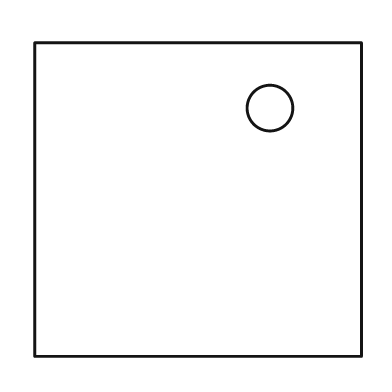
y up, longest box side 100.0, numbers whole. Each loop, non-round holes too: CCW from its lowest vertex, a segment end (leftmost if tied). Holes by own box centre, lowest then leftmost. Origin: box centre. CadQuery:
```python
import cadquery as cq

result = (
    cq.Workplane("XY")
    .moveTo(-50.0, -48.0)
    .lineTo(50.0, -48.0)
    .lineTo(50.0, 48.0)
    .lineTo(-50.0, 48.0)
    .close()
    .moveTo(22.0, 28.0)
    .circle(7.0)
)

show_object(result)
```